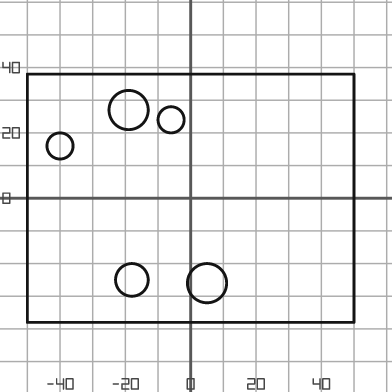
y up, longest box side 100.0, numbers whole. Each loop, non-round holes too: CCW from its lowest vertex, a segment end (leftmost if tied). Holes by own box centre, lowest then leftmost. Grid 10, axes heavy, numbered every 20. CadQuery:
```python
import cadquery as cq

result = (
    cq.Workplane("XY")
    .moveTo(-50.0, -38.0)
    .lineTo(50.0, -38.0)
    .lineTo(50.0, 38.0)
    .lineTo(-50.0, 38.0)
    .close()
    .moveTo(5.0, -26.0)
    .circle(6.0)
    .moveTo(-18.0, -25.0)
    .circle(5.0)
    .moveTo(-40.0, 16.0)
    .circle(4.0)
    .moveTo(-6.0, 24.0)
    .circle(4.0)
    .moveTo(-19.0, 27.0)
    .circle(6.0)
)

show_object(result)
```